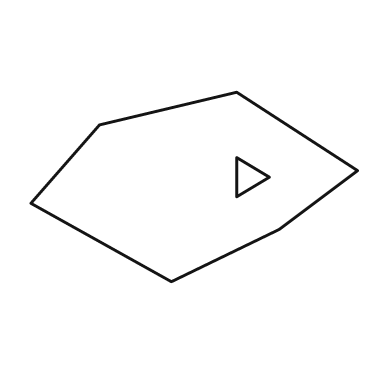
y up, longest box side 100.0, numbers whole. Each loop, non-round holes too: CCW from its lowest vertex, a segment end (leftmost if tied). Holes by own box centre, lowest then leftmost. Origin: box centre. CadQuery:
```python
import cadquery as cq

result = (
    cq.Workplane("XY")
    .moveTo(-7.0, -29.0)
    .lineTo(26.0, -13.0)
    .lineTo(50.0, 5.0)
    .lineTo(13.0, 29.0)
    .lineTo(-29.0, 19.0)
    .lineTo(-50.0, -5.0)
    .close()
    .moveTo(13.0, -3.0)
    .lineTo(23.0, 3.0)
    .lineTo(13.0, 9.0)
    .close()
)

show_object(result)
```